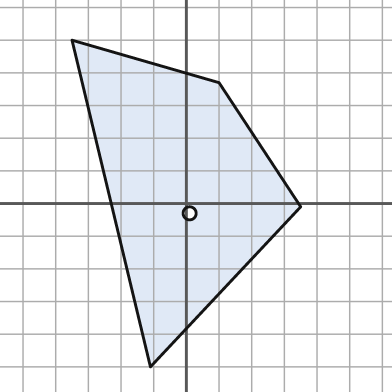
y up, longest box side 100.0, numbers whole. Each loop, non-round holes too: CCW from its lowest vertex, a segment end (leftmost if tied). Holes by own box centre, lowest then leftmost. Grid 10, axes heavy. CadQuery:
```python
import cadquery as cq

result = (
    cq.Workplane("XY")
    .moveTo(-11.0, -50.0)
    .lineTo(35.0, -1.0)
    .lineTo(10.0, 37.0)
    .lineTo(-35.0, 50.0)
    .close()
    .moveTo(1.0, -3.0)
    .circle(2.0)
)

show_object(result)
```